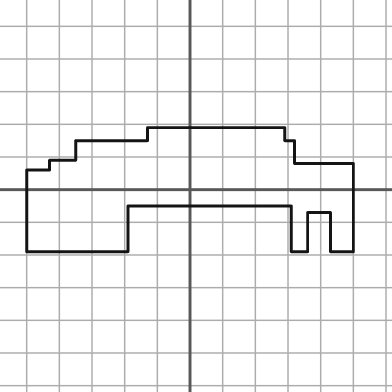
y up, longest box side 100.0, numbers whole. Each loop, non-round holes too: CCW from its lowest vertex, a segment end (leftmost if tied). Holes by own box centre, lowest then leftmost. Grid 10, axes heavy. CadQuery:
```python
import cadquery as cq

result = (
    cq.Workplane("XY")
    .moveTo(-50.0, -19.0)
    .lineTo(-19.0, -19.0)
    .lineTo(-19.0, -5.0)
    .lineTo(31.0, -5.0)
    .lineTo(31.0, -19.0)
    .lineTo(36.0, -19.0)
    .lineTo(36.0, -7.0)
    .lineTo(43.0, -7.0)
    .lineTo(43.0, -19.0)
    .lineTo(50.0, -19.0)
    .lineTo(50.0, 8.0)
    .lineTo(32.0, 8.0)
    .lineTo(32.0, 15.0)
    .lineTo(29.0, 15.0)
    .lineTo(29.0, 19.0)
    .lineTo(-13.0, 19.0)
    .lineTo(-13.0, 15.0)
    .lineTo(-35.0, 15.0)
    .lineTo(-35.0, 9.0)
    .lineTo(-43.0, 9.0)
    .lineTo(-43.0, 6.0)
    .lineTo(-50.0, 6.0)
    .close()
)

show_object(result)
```